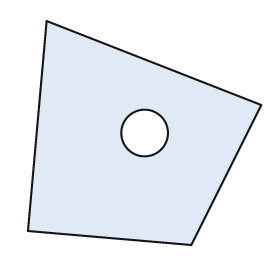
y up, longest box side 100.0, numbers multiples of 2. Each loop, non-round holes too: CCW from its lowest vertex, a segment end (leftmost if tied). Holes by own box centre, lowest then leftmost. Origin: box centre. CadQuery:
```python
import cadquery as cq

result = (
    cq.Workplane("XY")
    .moveTo(20.0, -48.0)
    .lineTo(50.0, 12.0)
    .lineTo(-42.0, 48.0)
    .lineTo(-50.0, -42.0)
    .close()
    .moveTo(0.0, 0.0)
    .circle(10.0)
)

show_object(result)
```